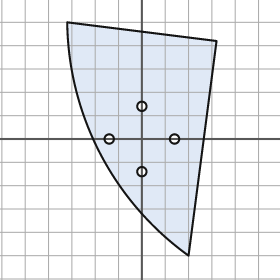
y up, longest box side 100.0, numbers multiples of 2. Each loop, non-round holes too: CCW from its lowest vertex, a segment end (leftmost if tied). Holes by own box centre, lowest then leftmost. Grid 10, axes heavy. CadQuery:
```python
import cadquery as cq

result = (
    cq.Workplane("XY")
    .moveTo(20.0, -50.0)
    .lineTo(32.0, 42.0)
    .lineTo(-32.0, 50.0)
    .threePointArc((-18.0, -6.0), (20.0, -50.0))
    .close()
    .moveTo(0.0, -14.0)
    .circle(2.0)
    .moveTo(-14.0, 0.0)
    .circle(2.0)
    .moveTo(14.0, 0.0)
    .circle(2.0)
    .moveTo(0.0, 14.0)
    .circle(2.0)
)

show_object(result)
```